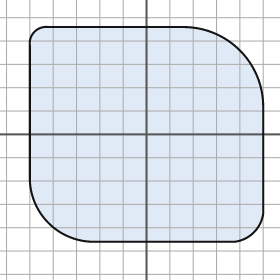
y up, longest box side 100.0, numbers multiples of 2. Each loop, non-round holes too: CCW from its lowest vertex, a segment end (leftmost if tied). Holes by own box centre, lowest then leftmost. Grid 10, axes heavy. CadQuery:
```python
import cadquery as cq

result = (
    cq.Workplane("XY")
    .moveTo(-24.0, -46.0)
    .lineTo(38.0, -46.0)
    .threePointArc((46.0, -42.0), (50.0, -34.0))
    .lineTo(50.0, 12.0)
    .threePointArc((40.0, 36.0), (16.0, 46.0))
    .lineTo(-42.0, 46.0)
    .threePointArc((-48.0, 44.0), (-50.0, 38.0))
    .lineTo(-50.0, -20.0)
    .threePointArc((-42.0, -38.0), (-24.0, -46.0))
    .close()
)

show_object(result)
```